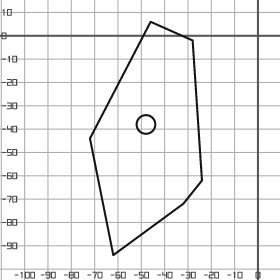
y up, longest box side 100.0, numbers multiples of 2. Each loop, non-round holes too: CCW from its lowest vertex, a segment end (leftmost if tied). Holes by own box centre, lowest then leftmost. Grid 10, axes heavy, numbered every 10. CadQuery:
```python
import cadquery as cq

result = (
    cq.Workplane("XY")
    .moveTo(-62.0, -94.0)
    .lineTo(-32.0, -72.0)
    .lineTo(-24.0, -62.0)
    .lineTo(-28.0, -2.0)
    .lineTo(-46.0, 6.0)
    .lineTo(-72.0, -44.0)
    .close()
    .moveTo(-48.0, -38.0)
    .circle(4.0)
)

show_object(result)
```